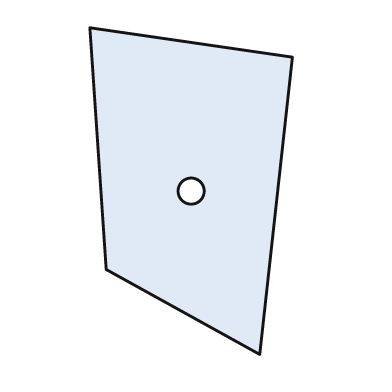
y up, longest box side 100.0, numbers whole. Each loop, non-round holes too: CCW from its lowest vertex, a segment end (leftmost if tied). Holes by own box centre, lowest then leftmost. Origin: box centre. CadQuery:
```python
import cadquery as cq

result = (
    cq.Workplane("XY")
    .moveTo(21.0, -50.0)
    .lineTo(31.0, 41.0)
    .lineTo(-31.0, 50.0)
    .lineTo(-26.0, -24.0)
    .close()
    .moveTo(0.0, 0.0)
    .circle(4.0)
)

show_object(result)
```